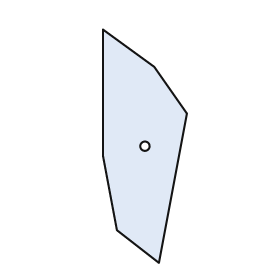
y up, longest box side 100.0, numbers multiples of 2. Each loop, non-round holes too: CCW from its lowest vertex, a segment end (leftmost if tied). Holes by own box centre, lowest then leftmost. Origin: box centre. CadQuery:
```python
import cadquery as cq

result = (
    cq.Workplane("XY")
    .moveTo(6.0, -50.0)
    .lineTo(18.0, 14.0)
    .lineTo(4.0, 34.0)
    .lineTo(-18.0, 50.0)
    .lineTo(-18.0, -4.0)
    .lineTo(-12.0, -36.0)
    .close()
    .moveTo(0.0, 0.0)
    .circle(2.0)
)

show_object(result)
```